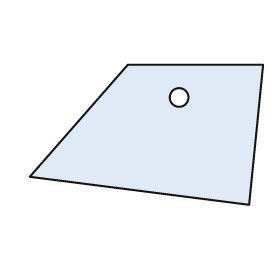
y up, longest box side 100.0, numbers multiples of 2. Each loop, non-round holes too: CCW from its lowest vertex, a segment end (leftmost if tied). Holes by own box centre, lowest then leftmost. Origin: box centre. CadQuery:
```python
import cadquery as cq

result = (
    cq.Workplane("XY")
    .moveTo(44.0, -30.0)
    .lineTo(50.0, 30.0)
    .lineTo(-8.0, 30.0)
    .lineTo(-50.0, -18.0)
    .close()
    .moveTo(14.0, 16.0)
    .circle(4.0)
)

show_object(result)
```